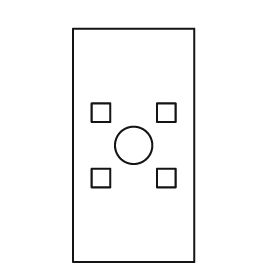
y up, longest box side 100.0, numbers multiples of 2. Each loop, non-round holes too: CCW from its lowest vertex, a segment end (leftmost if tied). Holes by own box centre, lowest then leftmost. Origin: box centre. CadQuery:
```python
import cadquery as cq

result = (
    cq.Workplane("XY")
    .moveTo(-26.0, -50.0)
    .lineTo(26.0, -50.0)
    .lineTo(26.0, 50.0)
    .lineTo(-26.0, 50.0)
    .close()
    .moveTo(-18.0, -18.0)
    .lineTo(-10.0, -18.0)
    .lineTo(-10.0, -10.0)
    .lineTo(-18.0, -10.0)
    .close()
    .moveTo(10.0, -18.0)
    .lineTo(18.0, -18.0)
    .lineTo(18.0, -10.0)
    .lineTo(10.0, -10.0)
    .close()
    .moveTo(0.0, 0.0)
    .circle(8.0)
    .moveTo(-18.0, 10.0)
    .lineTo(-10.0, 10.0)
    .lineTo(-10.0, 18.0)
    .lineTo(-18.0, 18.0)
    .close()
    .moveTo(10.0, 10.0)
    .lineTo(18.0, 10.0)
    .lineTo(18.0, 18.0)
    .lineTo(10.0, 18.0)
    .close()
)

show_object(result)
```